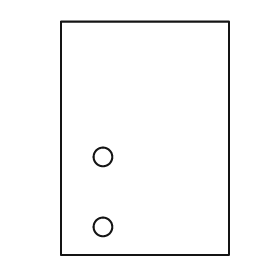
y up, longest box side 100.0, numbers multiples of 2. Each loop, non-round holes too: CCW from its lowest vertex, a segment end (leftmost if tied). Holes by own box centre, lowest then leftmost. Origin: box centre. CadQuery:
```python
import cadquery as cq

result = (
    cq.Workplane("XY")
    .moveTo(-36.0, -50.0)
    .lineTo(36.0, -50.0)
    .lineTo(36.0, 50.0)
    .lineTo(-36.0, 50.0)
    .close()
    .moveTo(-18.0, -38.0)
    .circle(4.0)
    .moveTo(-18.0, -8.0)
    .circle(4.0)
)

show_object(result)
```